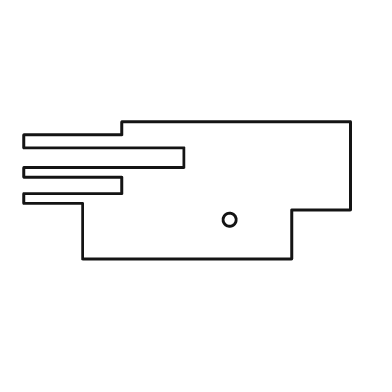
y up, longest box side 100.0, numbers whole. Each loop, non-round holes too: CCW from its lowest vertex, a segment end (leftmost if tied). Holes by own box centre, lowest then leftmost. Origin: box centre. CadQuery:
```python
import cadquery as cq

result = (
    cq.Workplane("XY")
    .moveTo(-32.0, -21.0)
    .lineTo(32.0, -21.0)
    .lineTo(32.0, -6.0)
    .lineTo(50.0, -6.0)
    .lineTo(50.0, 21.0)
    .lineTo(-20.0, 21.0)
    .lineTo(-20.0, 17.0)
    .lineTo(-50.0, 17.0)
    .lineTo(-50.0, 13.0)
    .lineTo(-1.0, 13.0)
    .lineTo(-1.0, 7.0)
    .lineTo(-50.0, 7.0)
    .lineTo(-50.0, 4.0)
    .lineTo(-20.0, 4.0)
    .lineTo(-20.0, -1.0)
    .lineTo(-50.0, -1.0)
    .lineTo(-50.0, -4.0)
    .lineTo(-32.0, -4.0)
    .close()
    .moveTo(13.0, -9.0)
    .circle(2.0)
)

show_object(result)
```